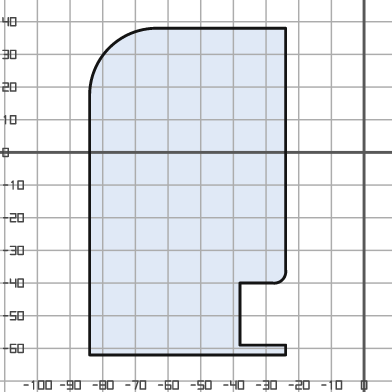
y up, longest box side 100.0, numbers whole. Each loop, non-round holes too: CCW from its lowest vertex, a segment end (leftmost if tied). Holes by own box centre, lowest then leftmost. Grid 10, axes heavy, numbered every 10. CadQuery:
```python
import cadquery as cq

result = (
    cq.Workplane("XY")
    .moveTo(-84.0, -62.0)
    .lineTo(-24.0, -62.0)
    .lineTo(-24.0, -59.0)
    .lineTo(-38.0, -59.0)
    .lineTo(-38.0, -40.0)
    .lineTo(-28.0, -40.0)
    .threePointArc((-25.0, -39.0), (-24.0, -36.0))
    .lineTo(-24.0, 38.0)
    .lineTo(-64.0, 38.0)
    .threePointArc((-78.0, 32.0), (-84.0, 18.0))
    .close()
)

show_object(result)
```